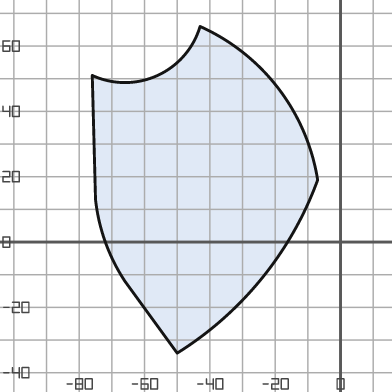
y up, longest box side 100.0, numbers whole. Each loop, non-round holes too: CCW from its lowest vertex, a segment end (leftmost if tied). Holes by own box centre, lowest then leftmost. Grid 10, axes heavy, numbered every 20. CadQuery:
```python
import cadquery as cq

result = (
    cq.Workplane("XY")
    .moveTo(-50.0, -34.0)
    .threePointArc((-24.0, -11.0), (-7.0, 19.0))
    .threePointArc((-19.0, 47.0), (-43.0, 66.0))
    .threePointArc((-56.0, 51.0), (-76.0, 51.0))
    .lineTo(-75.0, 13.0)
    .threePointArc((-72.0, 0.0), (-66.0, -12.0))
    .close()
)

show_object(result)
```